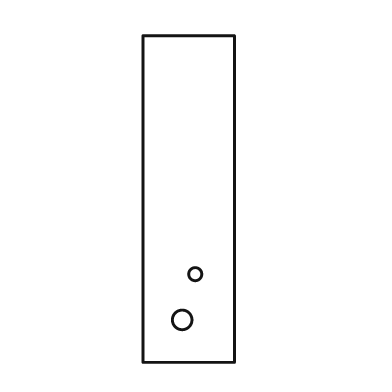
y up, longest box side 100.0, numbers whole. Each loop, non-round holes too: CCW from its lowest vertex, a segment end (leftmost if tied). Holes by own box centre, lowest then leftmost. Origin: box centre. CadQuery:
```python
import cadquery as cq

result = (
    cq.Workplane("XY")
    .moveTo(-14.0, -50.0)
    .lineTo(14.0, -50.0)
    .lineTo(14.0, 50.0)
    .lineTo(-14.0, 50.0)
    .close()
    .moveTo(-2.0, -37.0)
    .circle(3.0)
    .moveTo(2.0, -23.0)
    .circle(2.0)
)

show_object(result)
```